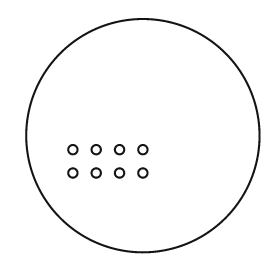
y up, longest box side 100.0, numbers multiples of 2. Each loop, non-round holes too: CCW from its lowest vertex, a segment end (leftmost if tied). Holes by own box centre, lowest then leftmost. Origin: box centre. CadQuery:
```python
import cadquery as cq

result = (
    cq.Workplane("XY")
    .moveTo(0.0, 0.0)
    .circle(50.0)
    .moveTo(-30.0, -16.0)
    .circle(2.0)
    .moveTo(-20.0, -16.0)
    .circle(2.0)
    .moveTo(-10.0, -16.0)
    .circle(2.0)
    .moveTo(0.0, -16.0)
    .circle(2.0)
    .moveTo(-30.0, -6.0)
    .circle(2.0)
    .moveTo(-20.0, -6.0)
    .circle(2.0)
    .moveTo(-10.0, -6.0)
    .circle(2.0)
    .moveTo(0.0, -6.0)
    .circle(2.0)
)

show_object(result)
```